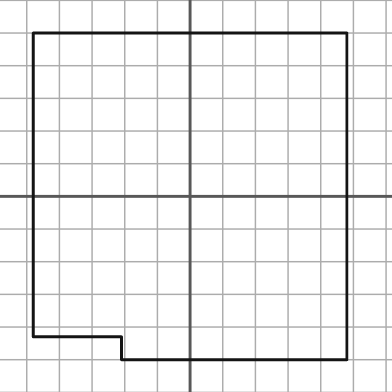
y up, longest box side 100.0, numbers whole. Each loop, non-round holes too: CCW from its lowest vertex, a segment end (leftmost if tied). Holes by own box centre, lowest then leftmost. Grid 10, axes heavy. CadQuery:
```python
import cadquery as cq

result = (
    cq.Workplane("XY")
    .moveTo(-21.0, -50.0)
    .lineTo(48.0, -50.0)
    .lineTo(48.0, 50.0)
    .lineTo(-48.0, 50.0)
    .lineTo(-48.0, -43.0)
    .lineTo(-21.0, -43.0)
    .close()
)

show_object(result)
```